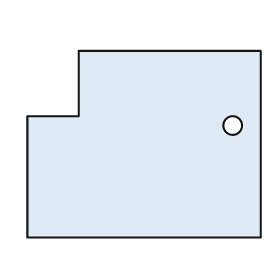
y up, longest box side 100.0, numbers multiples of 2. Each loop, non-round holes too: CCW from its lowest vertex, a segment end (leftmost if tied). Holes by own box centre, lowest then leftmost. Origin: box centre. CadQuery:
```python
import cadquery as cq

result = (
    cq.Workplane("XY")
    .moveTo(-50.0, -40.0)
    .lineTo(50.0, -40.0)
    .lineTo(50.0, 40.0)
    .lineTo(-28.0, 40.0)
    .lineTo(-28.0, 12.0)
    .lineTo(-50.0, 12.0)
    .close()
    .moveTo(38.0, 8.0)
    .circle(4.0)
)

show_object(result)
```